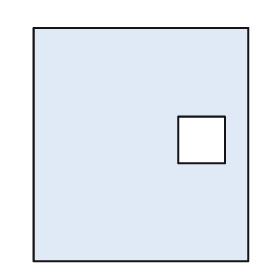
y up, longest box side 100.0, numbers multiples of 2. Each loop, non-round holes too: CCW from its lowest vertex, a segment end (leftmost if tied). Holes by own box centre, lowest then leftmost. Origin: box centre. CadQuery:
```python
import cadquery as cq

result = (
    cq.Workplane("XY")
    .moveTo(-46.0, -50.0)
    .lineTo(46.0, -50.0)
    .lineTo(46.0, 50.0)
    .lineTo(-46.0, 50.0)
    .close()
    .moveTo(16.0, -8.0)
    .lineTo(36.0, -8.0)
    .lineTo(36.0, 12.0)
    .lineTo(16.0, 12.0)
    .close()
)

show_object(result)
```